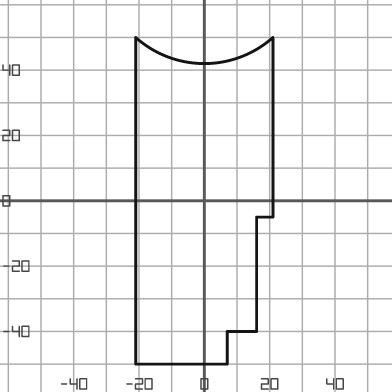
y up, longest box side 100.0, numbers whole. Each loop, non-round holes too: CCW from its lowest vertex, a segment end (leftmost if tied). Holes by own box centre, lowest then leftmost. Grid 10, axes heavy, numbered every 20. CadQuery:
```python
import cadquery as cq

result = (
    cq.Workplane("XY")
    .moveTo(-21.0, -50.0)
    .lineTo(7.0, -50.0)
    .lineTo(7.0, -40.0)
    .lineTo(16.0, -40.0)
    .lineTo(16.0, -5.0)
    .lineTo(21.0, -5.0)
    .lineTo(21.0, 50.0)
    .threePointArc((0.0, 42.0), (-21.0, 50.0))
    .close()
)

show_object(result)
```